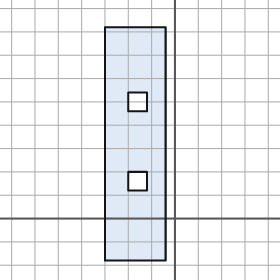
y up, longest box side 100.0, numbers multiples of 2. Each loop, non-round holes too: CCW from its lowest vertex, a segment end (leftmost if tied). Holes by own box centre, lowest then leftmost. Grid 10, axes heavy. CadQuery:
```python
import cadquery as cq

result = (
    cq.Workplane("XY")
    .moveTo(-30.0, -18.0)
    .lineTo(-4.0, -18.0)
    .lineTo(-4.0, 82.0)
    .lineTo(-30.0, 82.0)
    .close()
    .moveTo(-20.0, 12.0)
    .lineTo(-12.0, 12.0)
    .lineTo(-12.0, 20.0)
    .lineTo(-20.0, 20.0)
    .close()
    .moveTo(-20.0, 46.0)
    .lineTo(-12.0, 46.0)
    .lineTo(-12.0, 54.0)
    .lineTo(-20.0, 54.0)
    .close()
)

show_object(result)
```